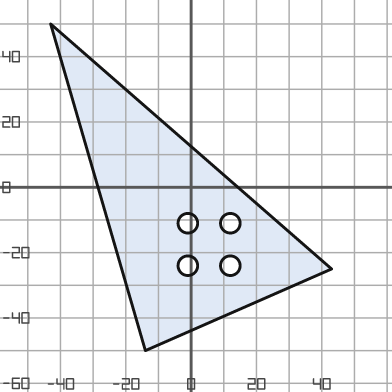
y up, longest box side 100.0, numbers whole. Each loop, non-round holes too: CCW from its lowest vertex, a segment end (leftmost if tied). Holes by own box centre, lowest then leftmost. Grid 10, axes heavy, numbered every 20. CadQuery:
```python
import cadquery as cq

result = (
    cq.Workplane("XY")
    .moveTo(-14.0, -50.0)
    .lineTo(43.0, -25.0)
    .lineTo(-43.0, 50.0)
    .close()
    .moveTo(-1.0, -24.0)
    .circle(3.0)
    .moveTo(12.0, -24.0)
    .circle(3.0)
    .moveTo(-1.0, -11.0)
    .circle(3.0)
    .moveTo(12.0, -11.0)
    .circle(3.0)
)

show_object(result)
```